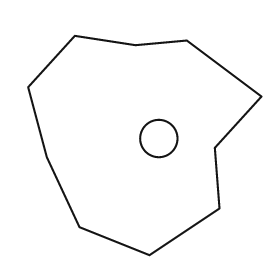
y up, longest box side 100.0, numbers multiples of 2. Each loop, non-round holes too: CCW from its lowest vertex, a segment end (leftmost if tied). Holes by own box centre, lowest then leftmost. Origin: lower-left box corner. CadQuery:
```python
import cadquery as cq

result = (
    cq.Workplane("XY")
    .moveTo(52.0, 0.0)
    .lineTo(82.0, 20.0)
    .lineTo(80.0, 46.0)
    .lineTo(100.0, 68.0)
    .lineTo(68.0, 92.0)
    .lineTo(46.0, 90.0)
    .lineTo(20.0, 94.0)
    .lineTo(0.0, 72.0)
    .lineTo(8.0, 42.0)
    .lineTo(22.0, 12.0)
    .close()
    .moveTo(56.0, 50.0)
    .circle(8.0)
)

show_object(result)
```